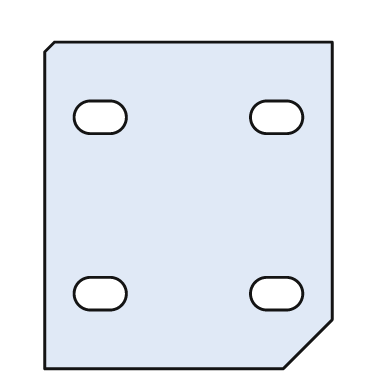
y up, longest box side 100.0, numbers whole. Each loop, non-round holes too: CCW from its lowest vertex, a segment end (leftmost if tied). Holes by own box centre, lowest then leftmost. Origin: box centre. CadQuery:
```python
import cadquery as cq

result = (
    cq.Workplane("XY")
    .moveTo(-44.0, -50.0)
    .lineTo(29.0, -50.0)
    .lineTo(44.0, -35.0)
    .lineTo(44.0, 50.0)
    .lineTo(-41.0, 50.0)
    .lineTo(-44.0, 47.0)
    .close()
    .moveTo(-30.0, -32.0)
    .lineTo(-24.0, -32.0)
    .threePointArc((-19.0, -27.0), (-24.0, -22.0))
    .lineTo(-30.0, -22.0)
    .threePointArc((-35.0, -27.0), (-30.0, -32.0))
    .close()
    .moveTo(24.0, -32.0)
    .lineTo(30.0, -32.0)
    .threePointArc((35.0, -27.0), (30.0, -22.0))
    .lineTo(24.0, -22.0)
    .threePointArc((19.0, -27.0), (24.0, -32.0))
    .close()
    .moveTo(-30.0, 22.0)
    .lineTo(-24.0, 22.0)
    .threePointArc((-19.0, 27.0), (-24.0, 32.0))
    .lineTo(-30.0, 32.0)
    .threePointArc((-35.0, 27.0), (-30.0, 22.0))
    .close()
    .moveTo(24.0, 22.0)
    .lineTo(30.0, 22.0)
    .threePointArc((35.0, 27.0), (30.0, 32.0))
    .lineTo(24.0, 32.0)
    .threePointArc((19.0, 27.0), (24.0, 22.0))
    .close()
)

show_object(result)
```